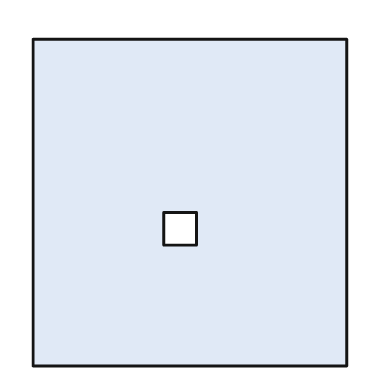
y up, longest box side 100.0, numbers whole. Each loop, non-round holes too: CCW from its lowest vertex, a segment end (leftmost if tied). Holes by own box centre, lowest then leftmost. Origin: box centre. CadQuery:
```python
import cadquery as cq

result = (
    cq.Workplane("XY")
    .moveTo(-48.0, -50.0)
    .lineTo(48.0, -50.0)
    .lineTo(48.0, 50.0)
    .lineTo(-48.0, 50.0)
    .close()
    .moveTo(-8.0, -13.0)
    .lineTo(2.0, -13.0)
    .lineTo(2.0, -3.0)
    .lineTo(-8.0, -3.0)
    .close()
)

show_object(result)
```